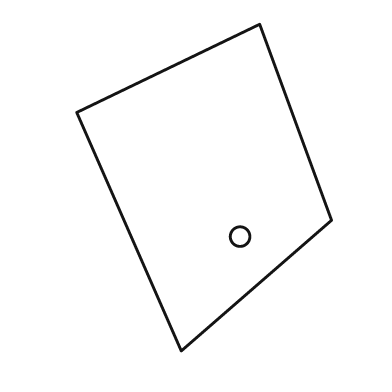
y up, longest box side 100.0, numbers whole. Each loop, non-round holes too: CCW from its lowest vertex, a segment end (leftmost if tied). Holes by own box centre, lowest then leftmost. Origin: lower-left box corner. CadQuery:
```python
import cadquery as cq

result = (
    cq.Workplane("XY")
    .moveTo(32.0, 0.0)
    .lineTo(78.0, 40.0)
    .lineTo(56.0, 100.0)
    .lineTo(0.0, 73.0)
    .close()
    .moveTo(50.0, 35.0)
    .circle(3.0)
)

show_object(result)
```